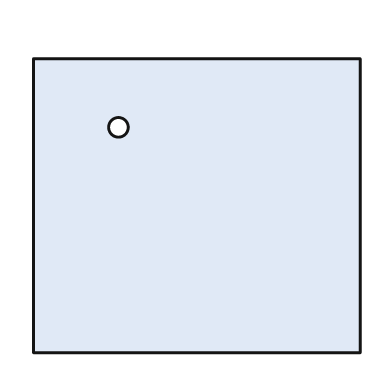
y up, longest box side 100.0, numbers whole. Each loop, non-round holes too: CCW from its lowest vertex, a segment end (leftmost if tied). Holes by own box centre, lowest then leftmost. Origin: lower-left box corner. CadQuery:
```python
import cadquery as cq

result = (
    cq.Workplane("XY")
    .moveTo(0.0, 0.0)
    .lineTo(100.0, 0.0)
    .lineTo(100.0, 90.0)
    .lineTo(0.0, 90.0)
    .close()
    .moveTo(26.0, 69.0)
    .circle(3.0)
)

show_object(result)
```